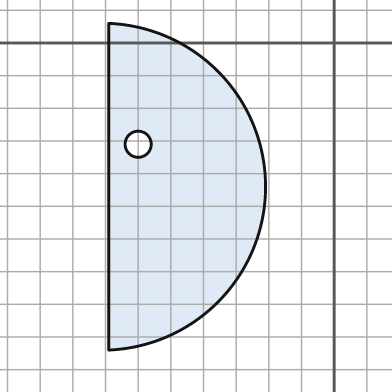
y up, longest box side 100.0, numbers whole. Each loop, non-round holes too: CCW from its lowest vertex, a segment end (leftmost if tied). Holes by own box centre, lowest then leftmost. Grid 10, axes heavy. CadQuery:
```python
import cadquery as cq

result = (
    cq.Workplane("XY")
    .moveTo(-69.0, -94.0)
    .threePointArc((-21.0, -44.0), (-69.0, 6.0))
    .close()
    .moveTo(-60.0, -31.0)
    .circle(4.0)
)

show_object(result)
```